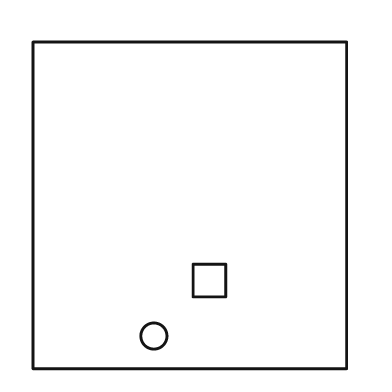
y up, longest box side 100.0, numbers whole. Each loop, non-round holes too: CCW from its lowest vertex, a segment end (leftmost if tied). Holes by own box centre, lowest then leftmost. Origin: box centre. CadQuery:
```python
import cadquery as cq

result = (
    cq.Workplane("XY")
    .moveTo(-48.0, -50.0)
    .lineTo(48.0, -50.0)
    .lineTo(48.0, 50.0)
    .lineTo(-48.0, 50.0)
    .close()
    .moveTo(-11.0, -40.0)
    .circle(4.0)
    .moveTo(1.0, -28.0)
    .lineTo(11.0, -28.0)
    .lineTo(11.0, -18.0)
    .lineTo(1.0, -18.0)
    .close()
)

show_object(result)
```